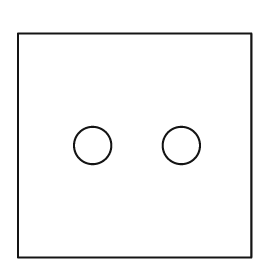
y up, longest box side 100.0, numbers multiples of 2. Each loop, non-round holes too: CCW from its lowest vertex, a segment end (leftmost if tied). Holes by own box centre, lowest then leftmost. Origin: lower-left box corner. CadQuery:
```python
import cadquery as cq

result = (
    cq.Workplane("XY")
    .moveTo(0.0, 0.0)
    .lineTo(100.0, 0.0)
    .lineTo(100.0, 96.0)
    .lineTo(0.0, 96.0)
    .close()
    .moveTo(32.0, 48.0)
    .circle(8.0)
    .moveTo(70.0, 48.0)
    .circle(8.0)
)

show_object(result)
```